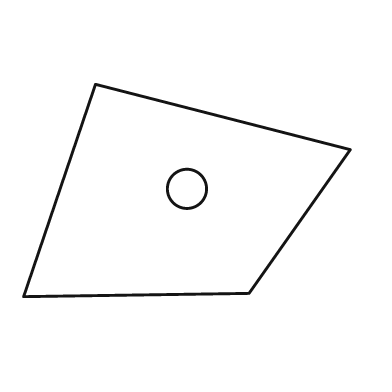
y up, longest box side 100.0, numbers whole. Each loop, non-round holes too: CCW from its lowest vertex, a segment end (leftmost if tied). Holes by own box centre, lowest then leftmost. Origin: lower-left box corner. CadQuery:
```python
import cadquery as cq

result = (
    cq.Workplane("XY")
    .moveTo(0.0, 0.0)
    .lineTo(69.0, 1.0)
    .lineTo(100.0, 45.0)
    .lineTo(22.0, 65.0)
    .close()
    .moveTo(50.0, 33.0)
    .circle(6.0)
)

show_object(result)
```